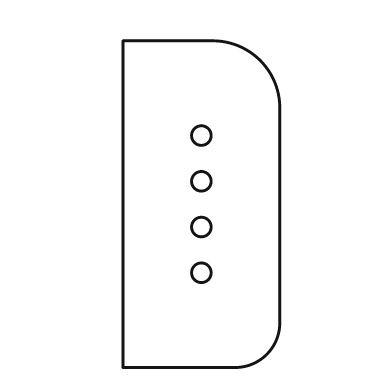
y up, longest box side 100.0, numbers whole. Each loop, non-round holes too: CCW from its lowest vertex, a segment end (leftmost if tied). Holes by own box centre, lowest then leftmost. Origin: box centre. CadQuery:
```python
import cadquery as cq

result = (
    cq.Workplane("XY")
    .moveTo(-24.0, -50.0)
    .lineTo(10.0, -50.0)
    .threePointArc((20.0, -46.0), (24.0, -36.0))
    .lineTo(24.0, 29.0)
    .threePointArc((18.0, 44.0), (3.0, 50.0))
    .lineTo(-24.0, 50.0)
    .close()
    .moveTo(0.0, -21.0)
    .circle(3.0)
    .moveTo(0.0, -7.0)
    .circle(3.0)
    .moveTo(0.0, 7.0)
    .circle(3.0)
    .moveTo(0.0, 21.0)
    .circle(3.0)
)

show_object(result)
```